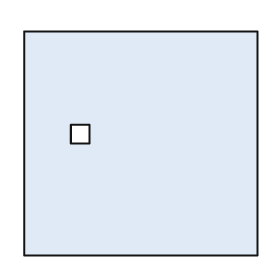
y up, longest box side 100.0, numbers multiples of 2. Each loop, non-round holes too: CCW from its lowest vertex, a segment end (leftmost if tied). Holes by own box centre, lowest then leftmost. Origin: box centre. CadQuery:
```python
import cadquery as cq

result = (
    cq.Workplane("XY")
    .moveTo(-50.0, -48.0)
    .lineTo(50.0, -48.0)
    .lineTo(50.0, 48.0)
    .lineTo(-50.0, 48.0)
    .close()
    .moveTo(-30.0, 0.0)
    .lineTo(-22.0, 0.0)
    .lineTo(-22.0, 8.0)
    .lineTo(-30.0, 8.0)
    .close()
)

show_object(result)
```